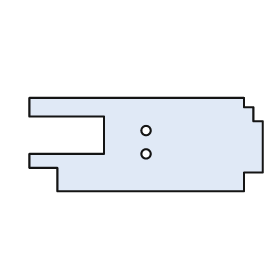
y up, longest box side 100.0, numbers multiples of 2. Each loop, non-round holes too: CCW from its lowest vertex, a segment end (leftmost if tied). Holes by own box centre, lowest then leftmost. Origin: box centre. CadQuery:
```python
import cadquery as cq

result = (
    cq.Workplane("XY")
    .moveTo(-38.0, -20.0)
    .lineTo(42.0, -20.0)
    .lineTo(42.0, -12.0)
    .lineTo(50.0, -12.0)
    .lineTo(50.0, 10.0)
    .lineTo(46.0, 10.0)
    .lineTo(46.0, 16.0)
    .lineTo(42.0, 16.0)
    .lineTo(42.0, 20.0)
    .lineTo(-50.0, 20.0)
    .lineTo(-50.0, 12.0)
    .lineTo(-18.0, 12.0)
    .lineTo(-18.0, -4.0)
    .lineTo(-50.0, -4.0)
    .lineTo(-50.0, -10.0)
    .lineTo(-38.0, -10.0)
    .close()
    .moveTo(0.0, -4.0)
    .circle(2.0)
    .moveTo(0.0, 6.0)
    .circle(2.0)
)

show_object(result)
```